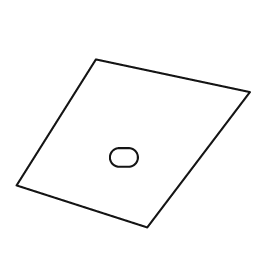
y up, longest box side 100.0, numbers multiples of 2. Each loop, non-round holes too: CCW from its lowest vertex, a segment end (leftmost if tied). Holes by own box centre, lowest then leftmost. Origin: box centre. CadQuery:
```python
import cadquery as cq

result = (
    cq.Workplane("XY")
    .moveTo(6.0, -36.0)
    .lineTo(50.0, 22.0)
    .lineTo(-16.0, 36.0)
    .lineTo(-50.0, -18.0)
    .close()
    .moveTo(-6.0, -10.0)
    .lineTo(-2.0, -10.0)
    .threePointArc((2.0, -6.0), (-2.0, -2.0))
    .lineTo(-6.0, -2.0)
    .threePointArc((-10.0, -6.0), (-6.0, -10.0))
    .close()
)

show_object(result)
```